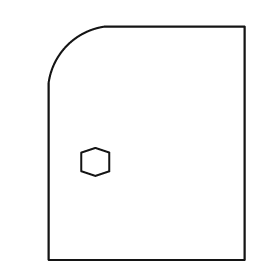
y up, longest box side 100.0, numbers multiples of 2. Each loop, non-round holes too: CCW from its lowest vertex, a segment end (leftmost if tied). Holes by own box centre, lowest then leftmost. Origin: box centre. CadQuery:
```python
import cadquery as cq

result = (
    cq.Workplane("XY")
    .moveTo(-42.0, -50.0)
    .lineTo(42.0, -50.0)
    .lineTo(42.0, 50.0)
    .lineTo(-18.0, 50.0)
    .threePointArc((-34.0, 42.0), (-42.0, 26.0))
    .close()
    .moveTo(-22.0, -14.0)
    .lineTo(-16.0, -12.0)
    .lineTo(-16.0, -4.0)
    .lineTo(-22.0, -2.0)
    .lineTo(-28.0, -4.0)
    .lineTo(-28.0, -12.0)
    .close()
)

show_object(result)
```